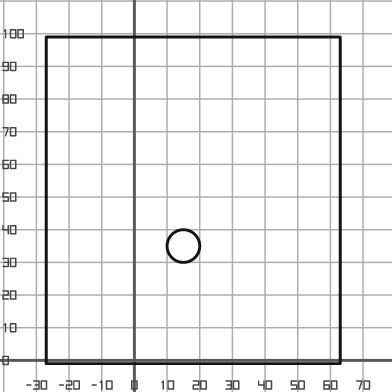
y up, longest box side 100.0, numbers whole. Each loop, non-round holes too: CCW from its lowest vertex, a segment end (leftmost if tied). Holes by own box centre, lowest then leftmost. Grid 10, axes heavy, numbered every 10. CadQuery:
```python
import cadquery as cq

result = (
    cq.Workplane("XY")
    .moveTo(-27.0, -1.0)
    .lineTo(63.0, -1.0)
    .lineTo(63.0, 99.0)
    .lineTo(-27.0, 99.0)
    .close()
    .moveTo(15.0, 35.0)
    .circle(5.0)
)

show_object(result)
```